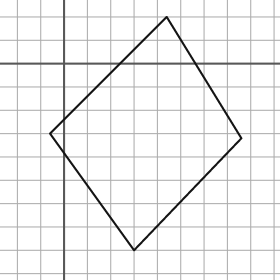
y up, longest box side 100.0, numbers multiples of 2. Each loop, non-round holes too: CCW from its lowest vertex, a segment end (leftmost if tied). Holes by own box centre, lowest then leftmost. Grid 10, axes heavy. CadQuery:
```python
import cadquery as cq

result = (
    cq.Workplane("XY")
    .moveTo(30.0, -80.0)
    .lineTo(76.0, -32.0)
    .lineTo(44.0, 20.0)
    .lineTo(-6.0, -30.0)
    .close()
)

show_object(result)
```